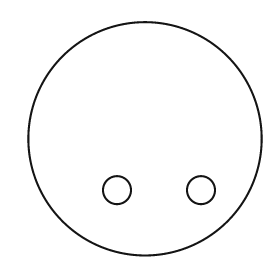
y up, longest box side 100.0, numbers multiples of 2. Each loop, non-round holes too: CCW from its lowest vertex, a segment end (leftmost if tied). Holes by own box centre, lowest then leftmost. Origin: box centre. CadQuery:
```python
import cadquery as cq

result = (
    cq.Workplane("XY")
    .moveTo(0.0, 0.0)
    .circle(50.0)
    .moveTo(-12.0, -22.0)
    .circle(6.0)
    .moveTo(24.0, -22.0)
    .circle(6.0)
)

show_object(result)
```